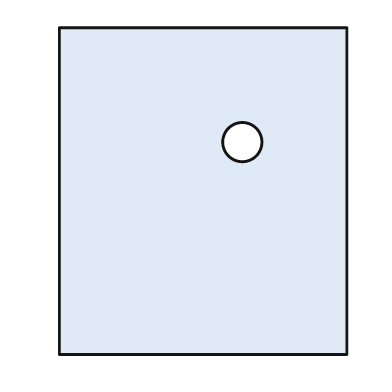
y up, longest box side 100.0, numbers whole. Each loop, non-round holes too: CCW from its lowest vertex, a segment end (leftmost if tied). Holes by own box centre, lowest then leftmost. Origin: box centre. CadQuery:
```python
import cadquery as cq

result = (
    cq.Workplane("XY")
    .moveTo(-44.0, -50.0)
    .lineTo(44.0, -50.0)
    .lineTo(44.0, 50.0)
    .lineTo(-44.0, 50.0)
    .close()
    .moveTo(12.0, 15.0)
    .circle(6.0)
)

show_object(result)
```